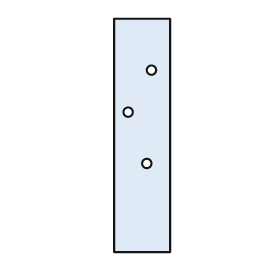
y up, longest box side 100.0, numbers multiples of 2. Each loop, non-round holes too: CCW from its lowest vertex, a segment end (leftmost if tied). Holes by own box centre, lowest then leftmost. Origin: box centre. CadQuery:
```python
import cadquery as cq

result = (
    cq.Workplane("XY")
    .moveTo(-12.0, -50.0)
    .lineTo(12.0, -50.0)
    .lineTo(12.0, 50.0)
    .lineTo(-12.0, 50.0)
    .close()
    .moveTo(2.0, -12.0)
    .circle(2.0)
    .moveTo(-6.0, 10.0)
    .circle(2.0)
    .moveTo(4.0, 28.0)
    .circle(2.0)
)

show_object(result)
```